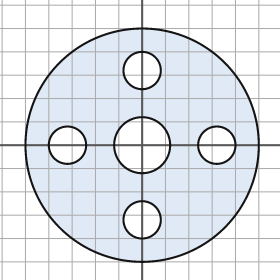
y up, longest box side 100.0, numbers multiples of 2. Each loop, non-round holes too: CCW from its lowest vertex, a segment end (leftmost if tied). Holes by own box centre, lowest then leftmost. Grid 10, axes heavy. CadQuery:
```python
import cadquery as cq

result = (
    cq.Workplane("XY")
    .moveTo(0.0, 0.0)
    .circle(50.0)
    .moveTo(0.0, -32.0)
    .circle(8.0)
    .moveTo(-32.0, 0.0)
    .circle(8.0)
    .moveTo(0.0, 0.0)
    .circle(12.0)
    .moveTo(32.0, 0.0)
    .circle(8.0)
    .moveTo(0.0, 32.0)
    .circle(8.0)
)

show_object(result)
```